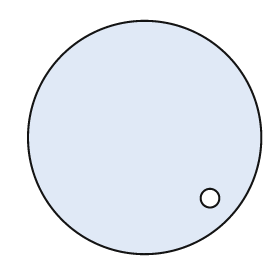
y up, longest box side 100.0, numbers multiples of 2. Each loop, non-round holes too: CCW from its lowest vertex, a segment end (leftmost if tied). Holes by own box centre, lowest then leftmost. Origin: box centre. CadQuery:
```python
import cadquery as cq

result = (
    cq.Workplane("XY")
    .moveTo(0.0, 0.0)
    .circle(50.0)
    .moveTo(28.0, -26.0)
    .circle(4.0)
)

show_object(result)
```